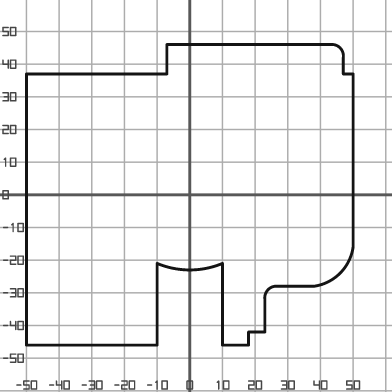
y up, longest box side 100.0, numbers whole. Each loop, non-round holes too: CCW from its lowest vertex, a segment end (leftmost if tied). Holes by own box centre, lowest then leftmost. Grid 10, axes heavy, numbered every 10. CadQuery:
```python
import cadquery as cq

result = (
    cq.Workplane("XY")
    .moveTo(-50.0, -46.0)
    .lineTo(-10.0, -46.0)
    .lineTo(-10.0, -21.0)
    .threePointArc((0.0, -23.0), (10.0, -21.0))
    .lineTo(10.0, -46.0)
    .lineTo(18.0, -46.0)
    .lineTo(18.0, -42.0)
    .lineTo(23.0, -42.0)
    .lineTo(23.0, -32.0)
    .threePointArc((24.0, -29.0), (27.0, -28.0))
    .lineTo(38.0, -28.0)
    .threePointArc((46.0, -24.0), (50.0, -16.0))
    .lineTo(50.0, 37.0)
    .lineTo(47.0, 37.0)
    .lineTo(47.0, 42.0)
    .threePointArc((46.0, 45.0), (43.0, 46.0))
    .lineTo(-7.0, 46.0)
    .lineTo(-7.0, 37.0)
    .lineTo(-50.0, 37.0)
    .close()
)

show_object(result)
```